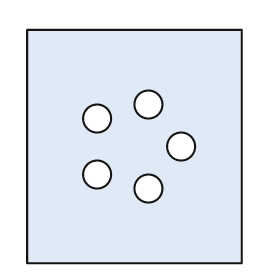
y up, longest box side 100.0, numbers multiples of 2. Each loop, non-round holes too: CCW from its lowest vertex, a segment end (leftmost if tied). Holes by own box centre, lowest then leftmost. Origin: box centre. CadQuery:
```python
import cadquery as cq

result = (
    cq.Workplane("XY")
    .moveTo(-46.0, -50.0)
    .lineTo(46.0, -50.0)
    .lineTo(46.0, 50.0)
    .lineTo(-46.0, 50.0)
    .close()
    .moveTo(6.0, -18.0)
    .circle(6.0)
    .moveTo(-16.0, -12.0)
    .circle(6.0)
    .moveTo(20.0, 0.0)
    .circle(6.0)
    .moveTo(-16.0, 12.0)
    .circle(6.0)
    .moveTo(6.0, 18.0)
    .circle(6.0)
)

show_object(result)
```